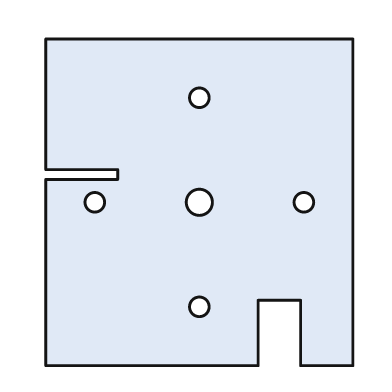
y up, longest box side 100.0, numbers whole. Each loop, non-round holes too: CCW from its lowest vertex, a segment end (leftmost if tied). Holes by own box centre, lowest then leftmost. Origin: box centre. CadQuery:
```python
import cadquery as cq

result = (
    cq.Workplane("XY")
    .moveTo(-47.0, -50.0)
    .lineTo(18.0, -50.0)
    .lineTo(18.0, -30.0)
    .lineTo(31.0, -30.0)
    .lineTo(31.0, -50.0)
    .lineTo(47.0, -50.0)
    .lineTo(47.0, 50.0)
    .lineTo(-47.0, 50.0)
    .lineTo(-47.0, 10.0)
    .lineTo(-25.0, 10.0)
    .lineTo(-25.0, 7.0)
    .lineTo(-47.0, 7.0)
    .close()
    .moveTo(0.0, -32.0)
    .circle(3.0)
    .moveTo(-32.0, 0.0)
    .circle(3.0)
    .moveTo(0.0, 0.0)
    .circle(4.0)
    .moveTo(32.0, 0.0)
    .circle(3.0)
    .moveTo(0.0, 32.0)
    .circle(3.0)
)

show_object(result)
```